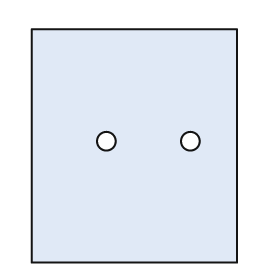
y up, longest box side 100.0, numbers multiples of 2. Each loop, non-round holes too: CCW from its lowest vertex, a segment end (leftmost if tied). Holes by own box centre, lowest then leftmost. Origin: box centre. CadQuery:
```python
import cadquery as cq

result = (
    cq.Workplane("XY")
    .moveTo(-44.0, -50.0)
    .lineTo(44.0, -50.0)
    .lineTo(44.0, 50.0)
    .lineTo(-44.0, 50.0)
    .close()
    .moveTo(-12.0, 2.0)
    .circle(4.0)
    .moveTo(24.0, 2.0)
    .circle(4.0)
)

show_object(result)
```